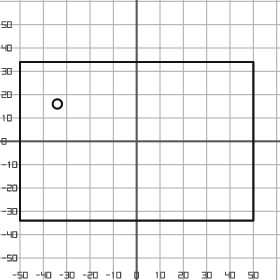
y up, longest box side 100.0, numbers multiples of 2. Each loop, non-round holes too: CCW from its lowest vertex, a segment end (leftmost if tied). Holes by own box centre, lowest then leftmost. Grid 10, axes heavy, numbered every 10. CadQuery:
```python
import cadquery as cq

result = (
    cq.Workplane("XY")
    .moveTo(-50.0, -34.0)
    .lineTo(50.0, -34.0)
    .lineTo(50.0, 34.0)
    .lineTo(-50.0, 34.0)
    .close()
    .moveTo(-34.0, 16.0)
    .circle(2.0)
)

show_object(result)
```